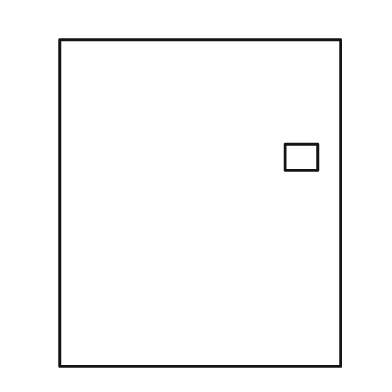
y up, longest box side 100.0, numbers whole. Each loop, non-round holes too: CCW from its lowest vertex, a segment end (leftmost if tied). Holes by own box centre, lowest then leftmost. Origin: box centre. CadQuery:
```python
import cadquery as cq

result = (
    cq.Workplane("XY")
    .moveTo(-43.0, -50.0)
    .lineTo(43.0, -50.0)
    .lineTo(43.0, 50.0)
    .lineTo(-43.0, 50.0)
    .close()
    .moveTo(26.0, 10.0)
    .lineTo(36.0, 10.0)
    .lineTo(36.0, 18.0)
    .lineTo(26.0, 18.0)
    .close()
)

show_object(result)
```